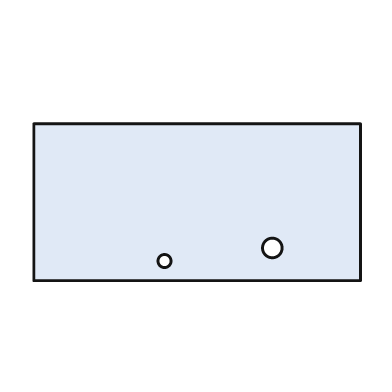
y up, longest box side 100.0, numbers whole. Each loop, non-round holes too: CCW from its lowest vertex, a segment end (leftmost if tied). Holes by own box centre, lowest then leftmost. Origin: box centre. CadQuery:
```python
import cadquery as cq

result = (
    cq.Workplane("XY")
    .moveTo(-50.0, -24.0)
    .lineTo(50.0, -24.0)
    .lineTo(50.0, 24.0)
    .lineTo(-50.0, 24.0)
    .close()
    .moveTo(-10.0, -18.0)
    .circle(2.0)
    .moveTo(23.0, -14.0)
    .circle(3.0)
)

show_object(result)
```